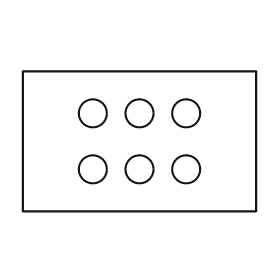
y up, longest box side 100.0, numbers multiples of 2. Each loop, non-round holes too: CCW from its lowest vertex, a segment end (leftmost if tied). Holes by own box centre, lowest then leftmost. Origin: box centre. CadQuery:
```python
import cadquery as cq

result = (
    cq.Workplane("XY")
    .moveTo(-50.0, -30.0)
    .lineTo(50.0, -30.0)
    .lineTo(50.0, 30.0)
    .lineTo(-50.0, 30.0)
    .close()
    .moveTo(-20.0, -12.0)
    .circle(6.0)
    .moveTo(0.0, -12.0)
    .circle(6.0)
    .moveTo(20.0, -12.0)
    .circle(6.0)
    .moveTo(-20.0, 12.0)
    .circle(6.0)
    .moveTo(0.0, 12.0)
    .circle(6.0)
    .moveTo(20.0, 12.0)
    .circle(6.0)
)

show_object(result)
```